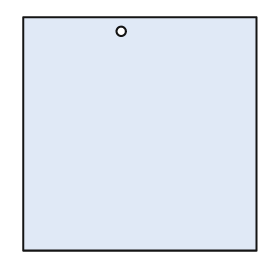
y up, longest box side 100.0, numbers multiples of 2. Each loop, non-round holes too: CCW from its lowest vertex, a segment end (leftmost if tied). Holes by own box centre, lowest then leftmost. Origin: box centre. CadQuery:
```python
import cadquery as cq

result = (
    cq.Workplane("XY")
    .moveTo(-50.0, -50.0)
    .lineTo(50.0, -50.0)
    .lineTo(50.0, 50.0)
    .lineTo(-50.0, 50.0)
    .close()
    .moveTo(-8.0, 44.0)
    .circle(2.0)
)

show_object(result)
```